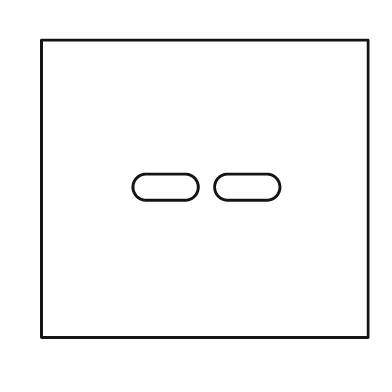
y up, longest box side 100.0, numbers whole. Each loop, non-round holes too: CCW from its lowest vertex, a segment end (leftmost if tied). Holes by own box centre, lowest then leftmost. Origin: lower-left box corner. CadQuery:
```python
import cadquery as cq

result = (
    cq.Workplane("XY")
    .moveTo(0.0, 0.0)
    .lineTo(100.0, 0.0)
    .lineTo(100.0, 91.0)
    .lineTo(0.0, 91.0)
    .close()
    .moveTo(32.0, 42.0)
    .lineTo(44.0, 42.0)
    .threePointArc((48.0, 46.0), (44.0, 50.0))
    .lineTo(32.0, 50.0)
    .threePointArc((28.0, 46.0), (32.0, 42.0))
    .close()
    .moveTo(57.0, 42.0)
    .lineTo(69.0, 42.0)
    .threePointArc((73.0, 46.0), (69.0, 50.0))
    .lineTo(57.0, 50.0)
    .threePointArc((53.0, 46.0), (57.0, 42.0))
    .close()
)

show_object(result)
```